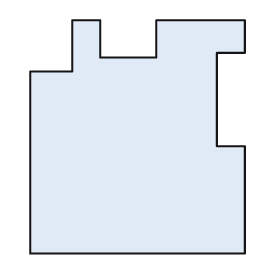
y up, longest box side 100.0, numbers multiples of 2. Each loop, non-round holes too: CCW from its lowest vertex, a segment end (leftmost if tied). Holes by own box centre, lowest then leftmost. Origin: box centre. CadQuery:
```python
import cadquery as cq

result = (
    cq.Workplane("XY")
    .moveTo(-46.0, -50.0)
    .lineTo(46.0, -50.0)
    .lineTo(46.0, -4.0)
    .lineTo(34.0, -4.0)
    .lineTo(34.0, 36.0)
    .lineTo(46.0, 36.0)
    .lineTo(46.0, 50.0)
    .lineTo(8.0, 50.0)
    .lineTo(8.0, 34.0)
    .lineTo(-16.0, 34.0)
    .lineTo(-16.0, 50.0)
    .lineTo(-28.0, 50.0)
    .lineTo(-28.0, 28.0)
    .lineTo(-46.0, 28.0)
    .close()
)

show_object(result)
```